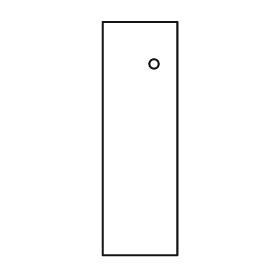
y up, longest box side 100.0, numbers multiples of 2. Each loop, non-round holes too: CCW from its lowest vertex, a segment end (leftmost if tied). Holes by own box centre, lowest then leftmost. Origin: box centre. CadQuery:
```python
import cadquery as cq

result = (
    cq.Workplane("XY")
    .moveTo(-16.0, -50.0)
    .lineTo(16.0, -50.0)
    .lineTo(16.0, 50.0)
    .lineTo(-16.0, 50.0)
    .close()
    .moveTo(6.0, 32.0)
    .circle(2.0)
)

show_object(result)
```